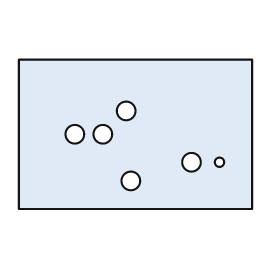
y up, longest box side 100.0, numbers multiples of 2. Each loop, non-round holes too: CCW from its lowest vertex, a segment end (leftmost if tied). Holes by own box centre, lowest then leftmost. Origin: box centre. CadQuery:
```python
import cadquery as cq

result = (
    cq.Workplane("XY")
    .moveTo(-50.0, -32.0)
    .lineTo(50.0, -32.0)
    .lineTo(50.0, 32.0)
    .lineTo(-50.0, 32.0)
    .close()
    .moveTo(-2.0, -20.0)
    .circle(4.0)
    .moveTo(24.0, -12.0)
    .circle(4.0)
    .moveTo(36.0, -12.0)
    .circle(2.0)
    .moveTo(-26.0, 0.0)
    .circle(4.0)
    .moveTo(-14.0, 0.0)
    .circle(4.0)
    .moveTo(-4.0, 10.0)
    .circle(4.0)
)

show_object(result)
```